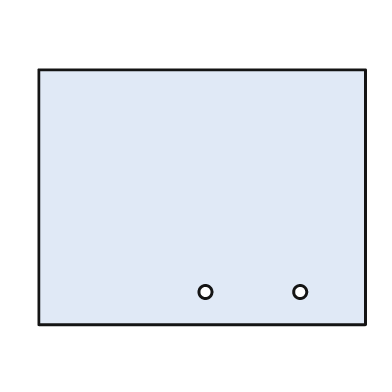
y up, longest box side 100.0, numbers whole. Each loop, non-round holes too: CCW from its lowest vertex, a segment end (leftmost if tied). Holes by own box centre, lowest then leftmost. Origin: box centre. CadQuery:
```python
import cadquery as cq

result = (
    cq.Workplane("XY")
    .moveTo(-50.0, -39.0)
    .lineTo(50.0, -39.0)
    .lineTo(50.0, 39.0)
    .lineTo(-50.0, 39.0)
    .close()
    .moveTo(1.0, -29.0)
    .circle(2.0)
    .moveTo(30.0, -29.0)
    .circle(2.0)
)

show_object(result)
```